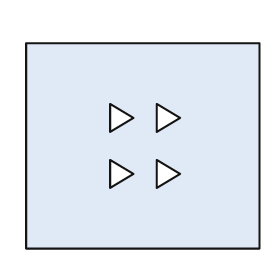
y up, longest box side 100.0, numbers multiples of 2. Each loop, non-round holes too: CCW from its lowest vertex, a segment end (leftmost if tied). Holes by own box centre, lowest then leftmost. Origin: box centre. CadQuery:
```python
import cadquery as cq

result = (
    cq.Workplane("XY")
    .moveTo(-50.0, -44.0)
    .lineTo(50.0, -44.0)
    .lineTo(50.0, 44.0)
    .lineTo(-50.0, 44.0)
    .close()
    .moveTo(-14.0, -18.0)
    .lineTo(-4.0, -12.0)
    .lineTo(-14.0, -6.0)
    .close()
    .moveTo(6.0, -18.0)
    .lineTo(16.0, -12.0)
    .lineTo(6.0, -6.0)
    .close()
    .moveTo(-14.0, 6.0)
    .lineTo(-4.0, 12.0)
    .lineTo(-14.0, 18.0)
    .close()
    .moveTo(6.0, 6.0)
    .lineTo(16.0, 12.0)
    .lineTo(6.0, 18.0)
    .close()
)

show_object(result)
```